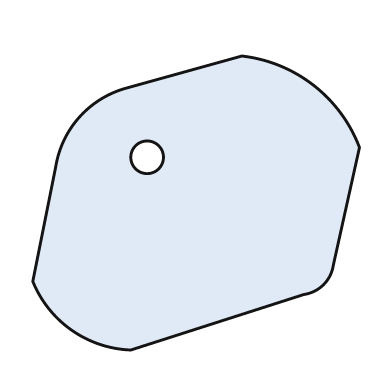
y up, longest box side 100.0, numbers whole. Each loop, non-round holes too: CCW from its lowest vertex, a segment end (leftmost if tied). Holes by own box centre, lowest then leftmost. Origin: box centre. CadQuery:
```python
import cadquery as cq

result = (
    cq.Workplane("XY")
    .moveTo(-20.0, -45.0)
    .lineTo(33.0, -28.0)
    .threePointArc((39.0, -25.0), (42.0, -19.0))
    .lineTo(50.0, 17.0)
    .threePointArc((36.0, 36.0), (14.0, 45.0))
    .lineTo(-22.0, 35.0)
    .threePointArc((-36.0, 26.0), (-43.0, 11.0))
    .lineTo(-50.0, -24.0)
    .threePointArc((-38.0, -39.0), (-20.0, -45.0))
    .close()
    .moveTo(-15.0, 14.0)
    .circle(5.0)
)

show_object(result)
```